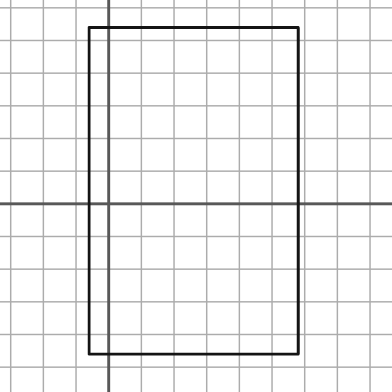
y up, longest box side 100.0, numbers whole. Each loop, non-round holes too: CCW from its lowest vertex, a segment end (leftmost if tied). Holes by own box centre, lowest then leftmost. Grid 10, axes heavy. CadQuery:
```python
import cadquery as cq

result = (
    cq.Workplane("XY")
    .moveTo(-6.0, -46.0)
    .lineTo(58.0, -46.0)
    .lineTo(58.0, 54.0)
    .lineTo(-6.0, 54.0)
    .close()
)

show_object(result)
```